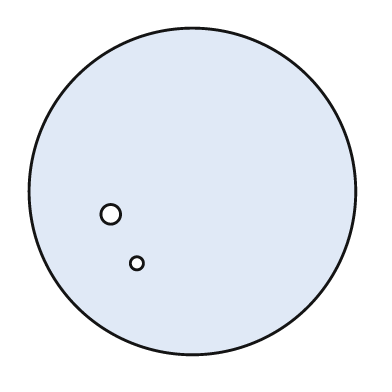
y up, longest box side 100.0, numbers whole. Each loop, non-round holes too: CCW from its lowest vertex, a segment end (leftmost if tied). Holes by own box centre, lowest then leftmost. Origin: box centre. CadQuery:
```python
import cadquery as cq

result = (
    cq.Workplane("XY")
    .moveTo(0.0, 0.0)
    .circle(50.0)
    .moveTo(-17.0, -22.0)
    .circle(2.0)
    .moveTo(-25.0, -7.0)
    .circle(3.0)
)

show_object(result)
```